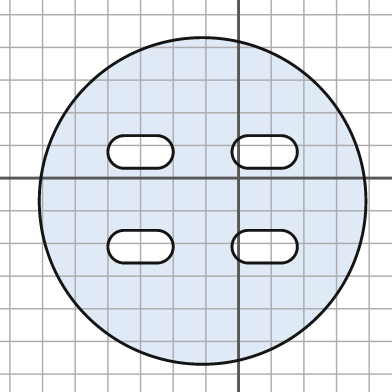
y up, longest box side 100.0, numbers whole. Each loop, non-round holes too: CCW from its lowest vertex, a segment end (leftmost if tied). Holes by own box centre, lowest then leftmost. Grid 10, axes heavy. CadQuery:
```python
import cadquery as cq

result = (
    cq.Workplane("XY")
    .moveTo(-11.0, -7.0)
    .circle(50.0)
    .moveTo(-35.0, -26.0)
    .lineTo(-25.0, -26.0)
    .threePointArc((-20.0, -21.0), (-25.0, -16.0))
    .lineTo(-35.0, -16.0)
    .threePointArc((-40.0, -21.0), (-35.0, -26.0))
    .close()
    .moveTo(3.0, -26.0)
    .lineTo(13.0, -26.0)
    .threePointArc((18.0, -21.0), (13.0, -16.0))
    .lineTo(3.0, -16.0)
    .threePointArc((-2.0, -21.0), (3.0, -26.0))
    .close()
    .moveTo(-35.0, 3.0)
    .lineTo(-25.0, 3.0)
    .threePointArc((-20.0, 8.0), (-25.0, 13.0))
    .lineTo(-35.0, 13.0)
    .threePointArc((-40.0, 8.0), (-35.0, 3.0))
    .close()
    .moveTo(3.0, 3.0)
    .lineTo(13.0, 3.0)
    .threePointArc((18.0, 8.0), (13.0, 13.0))
    .lineTo(3.0, 13.0)
    .threePointArc((-2.0, 8.0), (3.0, 3.0))
    .close()
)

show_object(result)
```